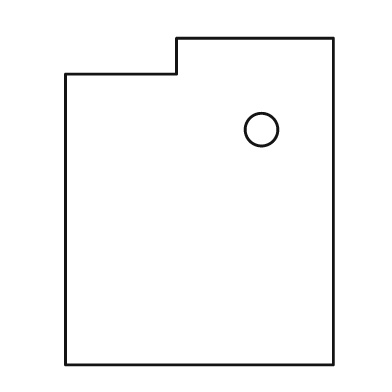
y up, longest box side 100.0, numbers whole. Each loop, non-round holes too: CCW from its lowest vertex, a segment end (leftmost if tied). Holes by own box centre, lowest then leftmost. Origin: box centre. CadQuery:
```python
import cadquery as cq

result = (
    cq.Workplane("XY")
    .moveTo(-41.0, -50.0)
    .lineTo(41.0, -50.0)
    .lineTo(41.0, 50.0)
    .lineTo(-7.0, 50.0)
    .lineTo(-7.0, 39.0)
    .lineTo(-41.0, 39.0)
    .close()
    .moveTo(19.0, 22.0)
    .circle(5.0)
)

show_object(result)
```